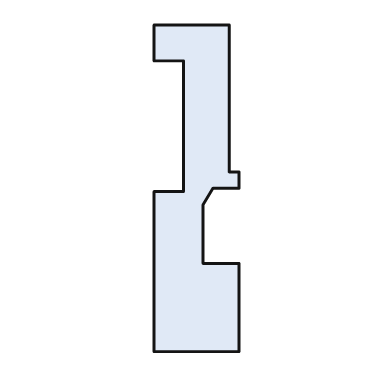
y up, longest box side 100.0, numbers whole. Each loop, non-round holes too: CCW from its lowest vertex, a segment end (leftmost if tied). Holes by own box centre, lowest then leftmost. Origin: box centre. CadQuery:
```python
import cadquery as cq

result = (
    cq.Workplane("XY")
    .moveTo(-13.0, -50.0)
    .lineTo(13.0, -50.0)
    .lineTo(13.0, -23.0)
    .lineTo(2.0, -23.0)
    .lineTo(2.0, -5.0)
    .lineTo(5.0, 0.0)
    .lineTo(13.0, 0.0)
    .lineTo(13.0, 5.0)
    .lineTo(10.0, 5.0)
    .lineTo(10.0, 50.0)
    .lineTo(-13.0, 50.0)
    .lineTo(-13.0, 39.0)
    .lineTo(-4.0, 39.0)
    .lineTo(-4.0, -1.0)
    .lineTo(-13.0, -1.0)
    .close()
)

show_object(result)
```